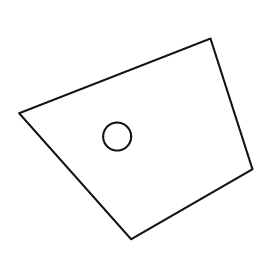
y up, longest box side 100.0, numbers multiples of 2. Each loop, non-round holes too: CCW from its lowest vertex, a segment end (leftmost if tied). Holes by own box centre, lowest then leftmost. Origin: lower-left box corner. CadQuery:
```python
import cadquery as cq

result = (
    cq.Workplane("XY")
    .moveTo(48.0, 0.0)
    .lineTo(100.0, 30.0)
    .lineTo(82.0, 86.0)
    .lineTo(0.0, 54.0)
    .close()
    .moveTo(42.0, 44.0)
    .circle(6.0)
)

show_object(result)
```